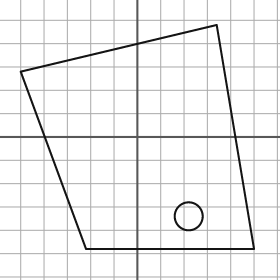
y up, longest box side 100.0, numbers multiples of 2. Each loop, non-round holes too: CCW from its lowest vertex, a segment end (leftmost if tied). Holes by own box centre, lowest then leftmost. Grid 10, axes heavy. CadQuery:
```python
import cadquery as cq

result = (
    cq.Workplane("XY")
    .moveTo(-22.0, -48.0)
    .lineTo(50.0, -48.0)
    .lineTo(34.0, 48.0)
    .lineTo(-50.0, 28.0)
    .close()
    .moveTo(22.0, -34.0)
    .circle(6.0)
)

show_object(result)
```